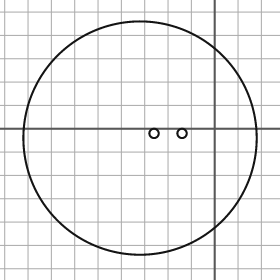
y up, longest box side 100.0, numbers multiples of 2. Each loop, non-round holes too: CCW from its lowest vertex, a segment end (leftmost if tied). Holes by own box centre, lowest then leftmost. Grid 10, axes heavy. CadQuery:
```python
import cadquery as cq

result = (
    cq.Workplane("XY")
    .moveTo(-32.0, -4.0)
    .circle(50.0)
    .moveTo(-26.0, -2.0)
    .circle(2.0)
    .moveTo(-14.0, -2.0)
    .circle(2.0)
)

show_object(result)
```